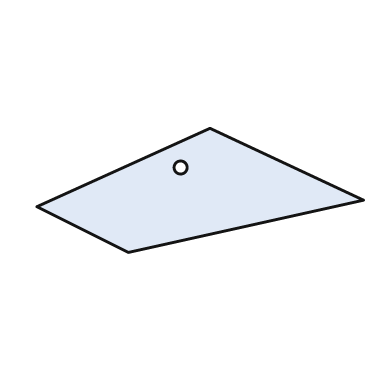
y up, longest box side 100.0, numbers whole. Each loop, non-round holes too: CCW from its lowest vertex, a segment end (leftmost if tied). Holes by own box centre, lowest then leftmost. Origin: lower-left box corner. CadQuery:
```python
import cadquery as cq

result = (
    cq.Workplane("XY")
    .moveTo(28.0, 0.0)
    .lineTo(100.0, 16.0)
    .lineTo(53.0, 38.0)
    .lineTo(0.0, 14.0)
    .close()
    .moveTo(44.0, 26.0)
    .circle(2.0)
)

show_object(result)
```